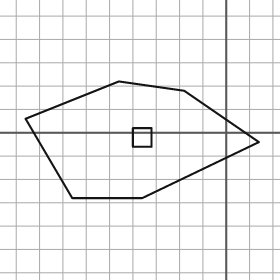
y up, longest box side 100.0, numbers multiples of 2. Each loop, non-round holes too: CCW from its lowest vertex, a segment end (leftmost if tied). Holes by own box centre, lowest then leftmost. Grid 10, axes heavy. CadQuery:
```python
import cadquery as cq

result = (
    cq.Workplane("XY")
    .moveTo(-66.0, -28.0)
    .lineTo(-36.0, -28.0)
    .lineTo(14.0, -4.0)
    .lineTo(-18.0, 18.0)
    .lineTo(-46.0, 22.0)
    .lineTo(-86.0, 6.0)
    .close()
    .moveTo(-40.0, -6.0)
    .lineTo(-32.0, -6.0)
    .lineTo(-32.0, 2.0)
    .lineTo(-40.0, 2.0)
    .close()
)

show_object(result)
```